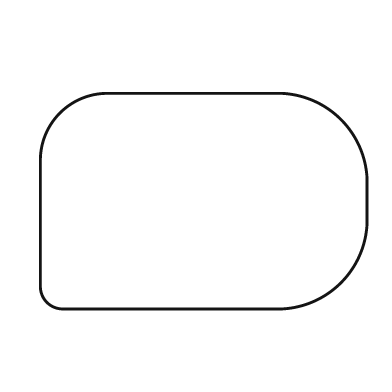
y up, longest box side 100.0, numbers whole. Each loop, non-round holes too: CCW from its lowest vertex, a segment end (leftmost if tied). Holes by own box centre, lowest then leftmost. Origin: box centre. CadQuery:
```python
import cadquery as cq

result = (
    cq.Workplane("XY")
    .moveTo(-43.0, -33.0)
    .lineTo(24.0, -33.0)
    .threePointArc((42.0, -25.0), (50.0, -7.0))
    .lineTo(50.0, 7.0)
    .threePointArc((42.0, 25.0), (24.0, 33.0))
    .lineTo(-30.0, 33.0)
    .threePointArc((-44.0, 27.0), (-50.0, 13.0))
    .lineTo(-50.0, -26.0)
    .threePointArc((-48.0, -31.0), (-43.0, -33.0))
    .close()
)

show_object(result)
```